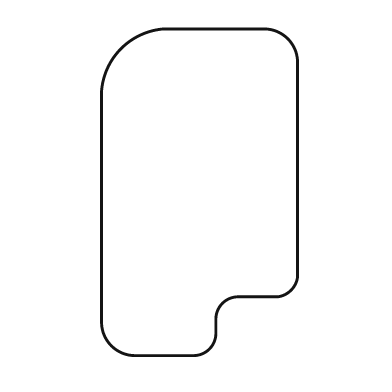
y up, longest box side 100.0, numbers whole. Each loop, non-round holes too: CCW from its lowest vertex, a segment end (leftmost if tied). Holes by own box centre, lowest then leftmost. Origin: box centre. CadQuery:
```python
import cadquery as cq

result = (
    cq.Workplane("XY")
    .moveTo(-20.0, -50.0)
    .lineTo(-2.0, -50.0)
    .threePointArc((3.0, -48.0), (5.0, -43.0))
    .lineTo(5.0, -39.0)
    .threePointArc((7.0, -34.0), (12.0, -32.0))
    .lineTo(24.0, -32.0)
    .threePointArc((28.0, -30.0), (30.0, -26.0))
    .lineTo(30.0, 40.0)
    .threePointArc((27.0, 47.0), (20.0, 50.0))
    .lineTo(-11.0, 50.0)
    .threePointArc((-24.0, 44.0), (-30.0, 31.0))
    .lineTo(-30.0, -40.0)
    .threePointArc((-27.0, -47.0), (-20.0, -50.0))
    .close()
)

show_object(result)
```